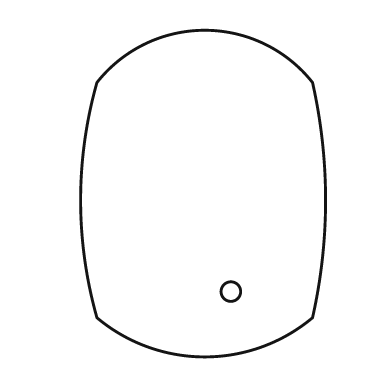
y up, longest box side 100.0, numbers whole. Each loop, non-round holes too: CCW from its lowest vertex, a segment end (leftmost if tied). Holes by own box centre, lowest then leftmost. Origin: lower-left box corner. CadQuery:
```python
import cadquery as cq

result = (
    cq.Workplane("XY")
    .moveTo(5.0, 12.0)
    .threePointArc((38.0, 0.0), (71.0, 12.0))
    .threePointArc((75.0, 48.0), (71.0, 84.0))
    .threePointArc((38.0, 100.0), (5.0, 84.0))
    .threePointArc((0.0, 48.0), (5.0, 12.0))
    .close()
    .moveTo(46.0, 20.0)
    .circle(3.0)
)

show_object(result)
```